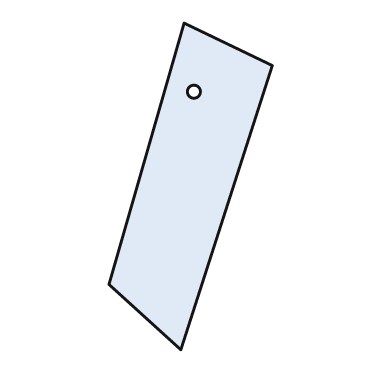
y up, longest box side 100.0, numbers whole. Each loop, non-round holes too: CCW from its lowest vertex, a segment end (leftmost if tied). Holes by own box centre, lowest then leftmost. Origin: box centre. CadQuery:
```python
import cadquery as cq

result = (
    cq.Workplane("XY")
    .moveTo(-3.0, -50.0)
    .lineTo(25.0, 37.0)
    .lineTo(-2.0, 50.0)
    .lineTo(-25.0, -30.0)
    .close()
    .moveTo(1.0, 29.0)
    .circle(2.0)
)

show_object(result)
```